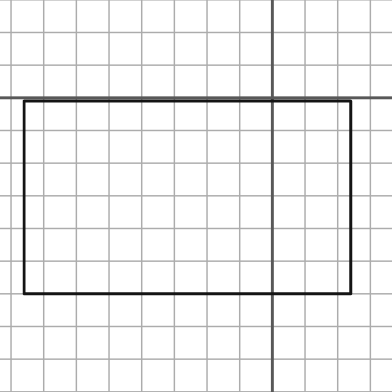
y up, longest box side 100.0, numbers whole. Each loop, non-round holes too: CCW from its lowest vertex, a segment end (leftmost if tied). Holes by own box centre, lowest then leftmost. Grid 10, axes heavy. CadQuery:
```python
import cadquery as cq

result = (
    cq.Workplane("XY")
    .moveTo(-76.0, -60.0)
    .lineTo(24.0, -60.0)
    .lineTo(24.0, -1.0)
    .lineTo(-76.0, -1.0)
    .close()
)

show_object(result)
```